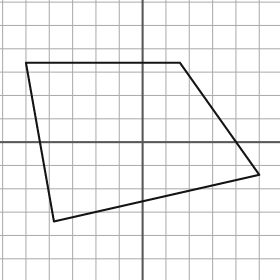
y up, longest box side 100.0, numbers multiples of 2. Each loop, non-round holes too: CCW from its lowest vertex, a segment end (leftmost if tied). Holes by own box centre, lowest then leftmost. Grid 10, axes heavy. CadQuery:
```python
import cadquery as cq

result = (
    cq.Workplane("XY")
    .moveTo(-38.0, -34.0)
    .lineTo(50.0, -14.0)
    .lineTo(16.0, 34.0)
    .lineTo(-50.0, 34.0)
    .close()
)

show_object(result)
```